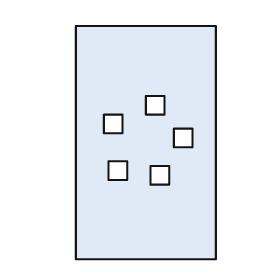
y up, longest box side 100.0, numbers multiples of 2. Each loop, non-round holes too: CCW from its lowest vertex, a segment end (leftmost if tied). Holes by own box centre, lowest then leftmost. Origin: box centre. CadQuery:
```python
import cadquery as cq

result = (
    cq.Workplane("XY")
    .moveTo(-30.0, -50.0)
    .lineTo(30.0, -50.0)
    .lineTo(30.0, 50.0)
    .lineTo(-30.0, 50.0)
    .close()
    .moveTo(2.0, -18.0)
    .lineTo(10.0, -18.0)
    .lineTo(10.0, -10.0)
    .lineTo(2.0, -10.0)
    .close()
    .moveTo(-16.0, -16.0)
    .lineTo(-8.0, -16.0)
    .lineTo(-8.0, -8.0)
    .lineTo(-16.0, -8.0)
    .close()
    .moveTo(12.0, -2.0)
    .lineTo(20.0, -2.0)
    .lineTo(20.0, 6.0)
    .lineTo(12.0, 6.0)
    .close()
    .moveTo(-18.0, 4.0)
    .lineTo(-10.0, 4.0)
    .lineTo(-10.0, 12.0)
    .lineTo(-18.0, 12.0)
    .close()
    .moveTo(0.0, 12.0)
    .lineTo(8.0, 12.0)
    .lineTo(8.0, 20.0)
    .lineTo(0.0, 20.0)
    .close()
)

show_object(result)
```